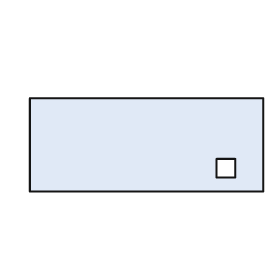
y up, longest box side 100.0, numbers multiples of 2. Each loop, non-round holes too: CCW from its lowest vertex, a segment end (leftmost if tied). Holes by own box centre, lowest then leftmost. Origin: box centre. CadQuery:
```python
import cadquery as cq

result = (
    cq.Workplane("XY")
    .moveTo(-50.0, -20.0)
    .lineTo(50.0, -20.0)
    .lineTo(50.0, 20.0)
    .lineTo(-50.0, 20.0)
    .close()
    .moveTo(30.0, -14.0)
    .lineTo(38.0, -14.0)
    .lineTo(38.0, -6.0)
    .lineTo(30.0, -6.0)
    .close()
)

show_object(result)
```